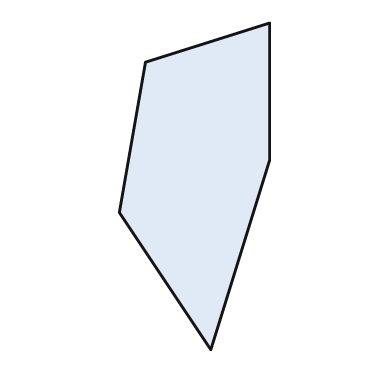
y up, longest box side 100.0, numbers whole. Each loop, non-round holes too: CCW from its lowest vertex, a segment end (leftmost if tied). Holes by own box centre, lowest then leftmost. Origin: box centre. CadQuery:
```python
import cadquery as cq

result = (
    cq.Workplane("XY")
    .moveTo(5.0, -50.0)
    .lineTo(23.0, 8.0)
    .lineTo(23.0, 50.0)
    .lineTo(-15.0, 38.0)
    .lineTo(-23.0, -8.0)
    .close()
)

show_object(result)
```